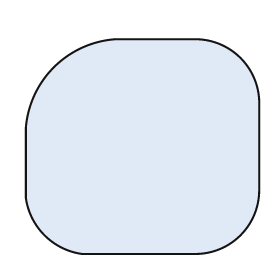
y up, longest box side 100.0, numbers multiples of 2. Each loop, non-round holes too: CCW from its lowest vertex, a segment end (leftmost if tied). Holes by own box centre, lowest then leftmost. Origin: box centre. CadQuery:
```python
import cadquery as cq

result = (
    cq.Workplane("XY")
    .moveTo(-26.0, -46.0)
    .lineTo(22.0, -46.0)
    .threePointArc((42.0, -38.0), (50.0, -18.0))
    .lineTo(50.0, 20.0)
    .threePointArc((42.0, 38.0), (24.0, 46.0))
    .lineTo(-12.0, 46.0)
    .threePointArc((-38.0, 34.0), (-50.0, 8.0))
    .lineTo(-50.0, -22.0)
    .threePointArc((-42.0, -38.0), (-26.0, -46.0))
    .close()
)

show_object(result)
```